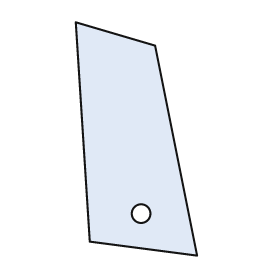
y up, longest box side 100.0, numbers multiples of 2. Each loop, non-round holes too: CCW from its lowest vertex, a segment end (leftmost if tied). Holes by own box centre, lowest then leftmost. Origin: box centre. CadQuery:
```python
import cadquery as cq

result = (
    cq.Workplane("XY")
    .moveTo(26.0, -50.0)
    .lineTo(8.0, 40.0)
    .lineTo(-26.0, 50.0)
    .lineTo(-20.0, -44.0)
    .close()
    .moveTo(2.0, -32.0)
    .circle(4.0)
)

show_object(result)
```